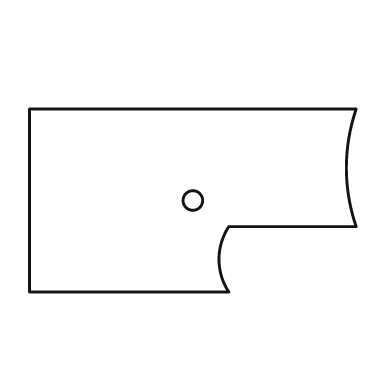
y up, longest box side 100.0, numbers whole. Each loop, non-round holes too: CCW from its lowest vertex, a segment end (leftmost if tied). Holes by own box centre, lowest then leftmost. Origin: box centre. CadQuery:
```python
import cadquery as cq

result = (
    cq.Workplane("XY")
    .moveTo(-50.0, -28.0)
    .lineTo(11.0, -28.0)
    .threePointArc((8.0, -18.0), (11.0, -8.0))
    .lineTo(50.0, -8.0)
    .threePointArc((47.0, 10.0), (50.0, 28.0))
    .lineTo(-50.0, 28.0)
    .close()
    .moveTo(0.0, 0.0)
    .circle(3.0)
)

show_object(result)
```